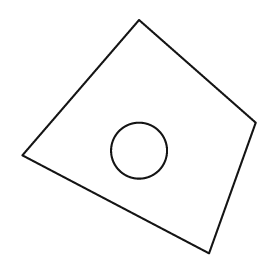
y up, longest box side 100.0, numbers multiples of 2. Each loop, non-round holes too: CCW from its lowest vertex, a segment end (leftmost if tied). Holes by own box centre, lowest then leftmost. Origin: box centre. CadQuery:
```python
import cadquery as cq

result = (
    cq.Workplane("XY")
    .moveTo(30.0, -50.0)
    .lineTo(50.0, 6.0)
    .lineTo(0.0, 50.0)
    .lineTo(-50.0, -8.0)
    .close()
    .moveTo(0.0, -6.0)
    .circle(12.0)
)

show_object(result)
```